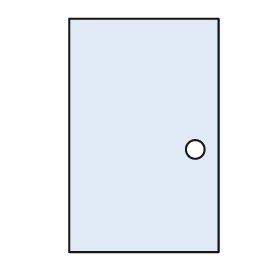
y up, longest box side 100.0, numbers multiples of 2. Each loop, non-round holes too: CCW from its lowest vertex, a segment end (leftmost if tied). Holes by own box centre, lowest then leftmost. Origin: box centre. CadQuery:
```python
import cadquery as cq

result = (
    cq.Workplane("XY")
    .moveTo(-32.0, -50.0)
    .lineTo(32.0, -50.0)
    .lineTo(32.0, 50.0)
    .lineTo(-32.0, 50.0)
    .close()
    .moveTo(22.0, -6.0)
    .circle(4.0)
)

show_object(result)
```